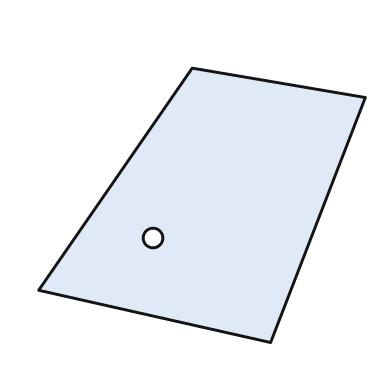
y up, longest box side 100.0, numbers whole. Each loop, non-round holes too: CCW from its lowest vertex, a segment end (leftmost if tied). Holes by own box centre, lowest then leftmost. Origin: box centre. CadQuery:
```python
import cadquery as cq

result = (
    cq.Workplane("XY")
    .moveTo(21.0, -42.0)
    .lineTo(50.0, 33.0)
    .lineTo(-3.0, 42.0)
    .lineTo(-50.0, -26.0)
    .close()
    .moveTo(-15.0, -10.0)
    .circle(3.0)
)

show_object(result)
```